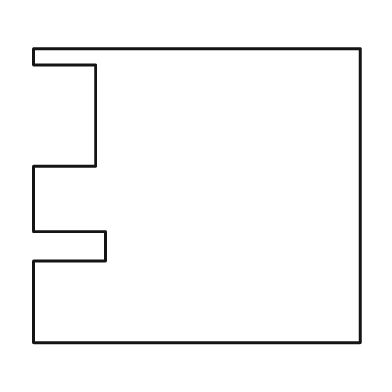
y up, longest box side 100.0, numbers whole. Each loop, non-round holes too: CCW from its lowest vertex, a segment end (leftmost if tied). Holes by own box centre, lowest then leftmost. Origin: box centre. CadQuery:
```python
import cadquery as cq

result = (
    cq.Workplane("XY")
    .moveTo(-50.0, -45.0)
    .lineTo(50.0, -45.0)
    .lineTo(50.0, 45.0)
    .lineTo(-50.0, 45.0)
    .lineTo(-50.0, 40.0)
    .lineTo(-31.0, 40.0)
    .lineTo(-31.0, 9.0)
    .lineTo(-50.0, 9.0)
    .lineTo(-50.0, -11.0)
    .lineTo(-28.0, -11.0)
    .lineTo(-28.0, -20.0)
    .lineTo(-50.0, -20.0)
    .close()
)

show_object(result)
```